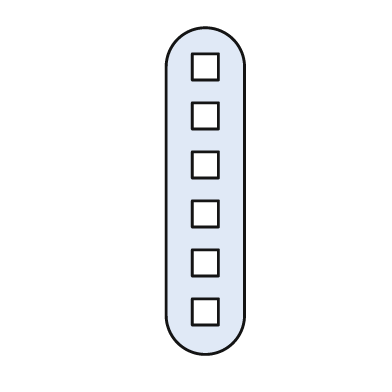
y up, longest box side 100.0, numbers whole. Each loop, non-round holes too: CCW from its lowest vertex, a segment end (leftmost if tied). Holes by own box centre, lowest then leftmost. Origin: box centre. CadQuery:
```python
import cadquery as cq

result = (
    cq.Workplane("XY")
    .moveTo(-12.0, -38.0)
    .threePointArc((0.0, -50.0), (12.0, -38.0))
    .lineTo(12.0, 38.0)
    .threePointArc((0.0, 50.0), (-12.0, 38.0))
    .close()
    .moveTo(-4.0, -41.0)
    .lineTo(4.0, -41.0)
    .lineTo(4.0, -33.0)
    .lineTo(-4.0, -33.0)
    .close()
    .moveTo(-4.0, -26.0)
    .lineTo(4.0, -26.0)
    .lineTo(4.0, -18.0)
    .lineTo(-4.0, -18.0)
    .close()
    .moveTo(-4.0, -11.0)
    .lineTo(4.0, -11.0)
    .lineTo(4.0, -3.0)
    .lineTo(-4.0, -3.0)
    .close()
    .moveTo(-4.0, 4.0)
    .lineTo(4.0, 4.0)
    .lineTo(4.0, 12.0)
    .lineTo(-4.0, 12.0)
    .close()
    .moveTo(-4.0, 19.0)
    .lineTo(4.0, 19.0)
    .lineTo(4.0, 27.0)
    .lineTo(-4.0, 27.0)
    .close()
    .moveTo(-4.0, 34.0)
    .lineTo(4.0, 34.0)
    .lineTo(4.0, 42.0)
    .lineTo(-4.0, 42.0)
    .close()
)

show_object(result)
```